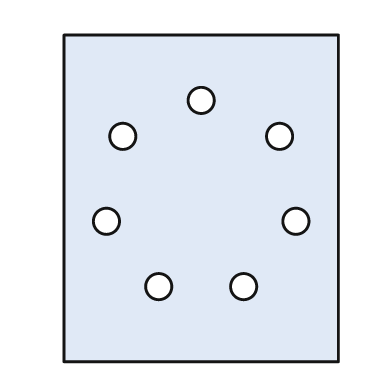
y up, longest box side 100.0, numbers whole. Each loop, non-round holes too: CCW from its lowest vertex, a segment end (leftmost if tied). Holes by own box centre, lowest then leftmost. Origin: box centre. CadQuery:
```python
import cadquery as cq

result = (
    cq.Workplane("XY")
    .moveTo(-42.0, -50.0)
    .lineTo(42.0, -50.0)
    .lineTo(42.0, 50.0)
    .lineTo(-42.0, 50.0)
    .close()
    .moveTo(-13.0, -27.0)
    .circle(4.0)
    .moveTo(13.0, -27.0)
    .circle(4.0)
    .moveTo(-29.0, -7.0)
    .circle(4.0)
    .moveTo(29.0, -7.0)
    .circle(4.0)
    .moveTo(-24.0, 19.0)
    .circle(4.0)
    .moveTo(24.0, 19.0)
    .circle(4.0)
    .moveTo(0.0, 30.0)
    .circle(4.0)
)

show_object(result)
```